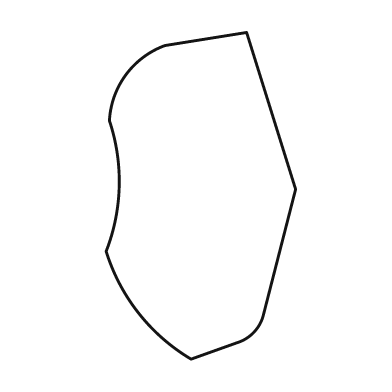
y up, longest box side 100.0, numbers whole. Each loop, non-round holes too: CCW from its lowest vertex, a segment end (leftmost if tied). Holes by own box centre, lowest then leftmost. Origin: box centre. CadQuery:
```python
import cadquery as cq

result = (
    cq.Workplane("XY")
    .moveTo(-3.0, -50.0)
    .lineTo(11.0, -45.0)
    .threePointArc((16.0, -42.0), (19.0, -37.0))
    .lineTo(29.0, 2.0)
    .lineTo(14.0, 50.0)
    .lineTo(-11.0, 46.0)
    .threePointArc((-23.0, 37.0), (-28.0, 23.0))
    .threePointArc((-25.0, 3.0), (-29.0, -17.0))
    .threePointArc((-19.0, -36.0), (-3.0, -50.0))
    .close()
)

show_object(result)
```